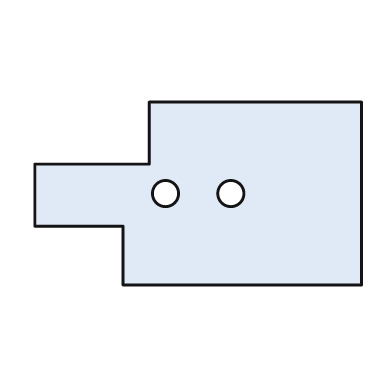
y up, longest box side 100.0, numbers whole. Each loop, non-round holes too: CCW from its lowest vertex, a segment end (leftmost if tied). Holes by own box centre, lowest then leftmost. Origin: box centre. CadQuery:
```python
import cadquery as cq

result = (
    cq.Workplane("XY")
    .moveTo(-23.0, -28.0)
    .lineTo(50.0, -28.0)
    .lineTo(50.0, 28.0)
    .lineTo(-15.0, 28.0)
    .lineTo(-15.0, 9.0)
    .lineTo(-50.0, 9.0)
    .lineTo(-50.0, -10.0)
    .lineTo(-23.0, -10.0)
    .close()
    .moveTo(-10.0, 0.0)
    .circle(4.0)
    .moveTo(10.0, 0.0)
    .circle(4.0)
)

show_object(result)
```